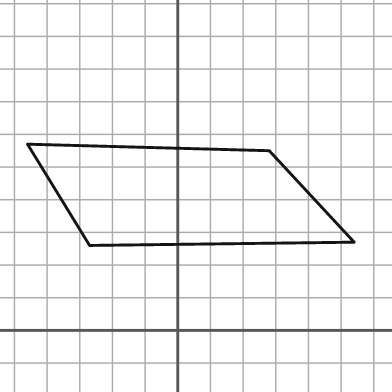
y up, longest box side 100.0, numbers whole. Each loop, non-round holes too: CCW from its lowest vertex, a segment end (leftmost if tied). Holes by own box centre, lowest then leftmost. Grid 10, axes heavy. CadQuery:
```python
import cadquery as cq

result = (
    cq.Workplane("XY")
    .moveTo(-27.0, 26.0)
    .lineTo(54.0, 27.0)
    .lineTo(28.0, 55.0)
    .lineTo(-46.0, 57.0)
    .close()
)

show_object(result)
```